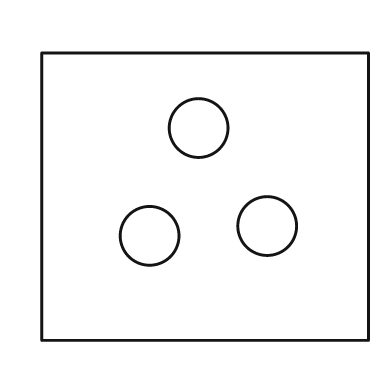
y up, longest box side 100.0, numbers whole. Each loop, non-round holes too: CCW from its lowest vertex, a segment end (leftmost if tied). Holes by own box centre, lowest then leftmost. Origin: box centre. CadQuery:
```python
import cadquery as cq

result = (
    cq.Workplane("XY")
    .moveTo(-50.0, -44.0)
    .lineTo(50.0, -44.0)
    .lineTo(50.0, 44.0)
    .lineTo(-50.0, 44.0)
    .close()
    .moveTo(-17.0, -12.0)
    .circle(9.0)
    .moveTo(19.0, -9.0)
    .circle(9.0)
    .moveTo(-2.0, 21.0)
    .circle(9.0)
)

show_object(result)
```